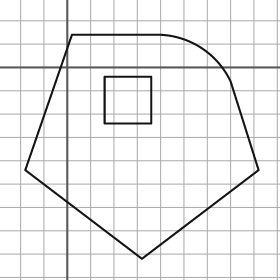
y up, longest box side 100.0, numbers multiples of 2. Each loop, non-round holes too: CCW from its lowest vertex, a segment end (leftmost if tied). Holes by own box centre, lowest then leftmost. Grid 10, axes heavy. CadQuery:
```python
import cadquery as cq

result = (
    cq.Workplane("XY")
    .moveTo(32.0, -82.0)
    .lineTo(82.0, -44.0)
    .lineTo(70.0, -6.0)
    .threePointArc((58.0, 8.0), (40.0, 14.0))
    .lineTo(2.0, 14.0)
    .lineTo(-18.0, -44.0)
    .close()
    .moveTo(16.0, -24.0)
    .lineTo(36.0, -24.0)
    .lineTo(36.0, -4.0)
    .lineTo(16.0, -4.0)
    .close()
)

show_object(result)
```